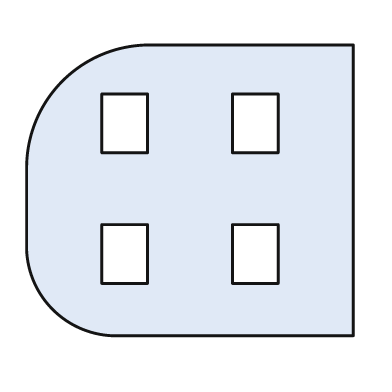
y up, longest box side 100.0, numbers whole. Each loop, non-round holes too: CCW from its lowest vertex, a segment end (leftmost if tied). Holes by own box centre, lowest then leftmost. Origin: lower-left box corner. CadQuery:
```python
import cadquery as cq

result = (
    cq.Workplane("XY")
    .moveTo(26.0, 0.0)
    .lineTo(100.0, 0.0)
    .lineTo(100.0, 89.0)
    .lineTo(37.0, 89.0)
    .threePointArc((11.0, 78.0), (0.0, 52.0))
    .lineTo(0.0, 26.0)
    .threePointArc((8.0, 8.0), (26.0, 0.0))
    .close()
    .moveTo(23.0, 16.0)
    .lineTo(37.0, 16.0)
    .lineTo(37.0, 34.0)
    .lineTo(23.0, 34.0)
    .close()
    .moveTo(63.0, 16.0)
    .lineTo(77.0, 16.0)
    .lineTo(77.0, 34.0)
    .lineTo(63.0, 34.0)
    .close()
    .moveTo(23.0, 56.0)
    .lineTo(37.0, 56.0)
    .lineTo(37.0, 74.0)
    .lineTo(23.0, 74.0)
    .close()
    .moveTo(63.0, 56.0)
    .lineTo(77.0, 56.0)
    .lineTo(77.0, 74.0)
    .lineTo(63.0, 74.0)
    .close()
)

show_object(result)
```